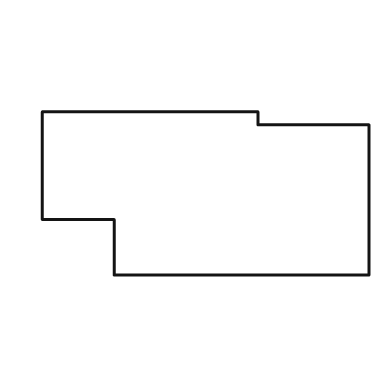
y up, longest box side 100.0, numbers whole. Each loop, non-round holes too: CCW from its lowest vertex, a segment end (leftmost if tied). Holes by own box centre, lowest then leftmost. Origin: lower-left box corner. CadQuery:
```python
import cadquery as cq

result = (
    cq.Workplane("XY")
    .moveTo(22.0, 0.0)
    .lineTo(100.0, 0.0)
    .lineTo(100.0, 46.0)
    .lineTo(66.0, 46.0)
    .lineTo(66.0, 50.0)
    .lineTo(0.0, 50.0)
    .lineTo(0.0, 17.0)
    .lineTo(22.0, 17.0)
    .close()
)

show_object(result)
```